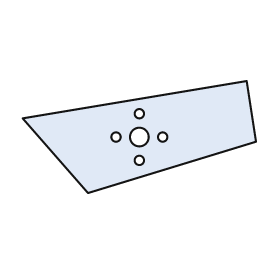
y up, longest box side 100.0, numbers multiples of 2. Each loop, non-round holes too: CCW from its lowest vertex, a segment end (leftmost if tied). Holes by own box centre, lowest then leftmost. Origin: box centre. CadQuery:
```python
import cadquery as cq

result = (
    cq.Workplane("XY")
    .moveTo(-22.0, -24.0)
    .lineTo(50.0, -2.0)
    .lineTo(46.0, 24.0)
    .lineTo(-50.0, 8.0)
    .close()
    .moveTo(0.0, -10.0)
    .circle(2.0)
    .moveTo(-10.0, 0.0)
    .circle(2.0)
    .moveTo(0.0, 0.0)
    .circle(4.0)
    .moveTo(10.0, 0.0)
    .circle(2.0)
    .moveTo(0.0, 10.0)
    .circle(2.0)
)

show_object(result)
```